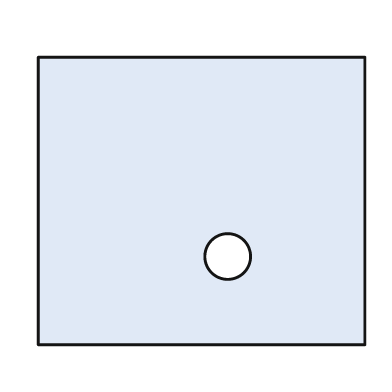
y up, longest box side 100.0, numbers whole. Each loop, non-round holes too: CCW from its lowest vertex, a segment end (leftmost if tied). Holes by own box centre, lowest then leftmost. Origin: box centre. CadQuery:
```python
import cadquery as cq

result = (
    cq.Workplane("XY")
    .moveTo(-50.0, -44.0)
    .lineTo(50.0, -44.0)
    .lineTo(50.0, 44.0)
    .lineTo(-50.0, 44.0)
    .close()
    .moveTo(8.0, -17.0)
    .circle(7.0)
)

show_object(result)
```